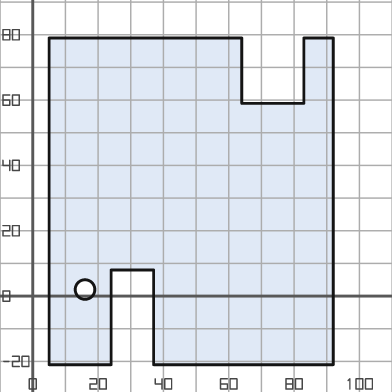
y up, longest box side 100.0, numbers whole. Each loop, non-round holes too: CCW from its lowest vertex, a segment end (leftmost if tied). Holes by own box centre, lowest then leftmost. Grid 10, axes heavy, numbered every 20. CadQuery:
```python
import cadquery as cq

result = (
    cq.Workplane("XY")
    .moveTo(5.0, -21.0)
    .lineTo(24.0, -21.0)
    .lineTo(24.0, 8.0)
    .lineTo(37.0, 8.0)
    .lineTo(37.0, -21.0)
    .lineTo(92.0, -21.0)
    .lineTo(92.0, 79.0)
    .lineTo(83.0, 79.0)
    .lineTo(83.0, 59.0)
    .lineTo(64.0, 59.0)
    .lineTo(64.0, 79.0)
    .lineTo(5.0, 79.0)
    .close()
    .moveTo(16.0, 2.0)
    .circle(3.0)
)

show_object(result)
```